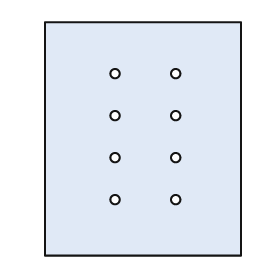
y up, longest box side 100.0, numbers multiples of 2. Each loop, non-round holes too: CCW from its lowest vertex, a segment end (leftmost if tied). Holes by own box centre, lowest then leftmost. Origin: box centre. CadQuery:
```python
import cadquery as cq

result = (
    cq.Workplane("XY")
    .moveTo(-42.0, -50.0)
    .lineTo(42.0, -50.0)
    .lineTo(42.0, 50.0)
    .lineTo(-42.0, 50.0)
    .close()
    .moveTo(-12.0, -26.0)
    .circle(2.0)
    .moveTo(14.0, -26.0)
    .circle(2.0)
    .moveTo(-12.0, -8.0)
    .circle(2.0)
    .moveTo(14.0, -8.0)
    .circle(2.0)
    .moveTo(-12.0, 10.0)
    .circle(2.0)
    .moveTo(14.0, 10.0)
    .circle(2.0)
    .moveTo(-12.0, 28.0)
    .circle(2.0)
    .moveTo(14.0, 28.0)
    .circle(2.0)
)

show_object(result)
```